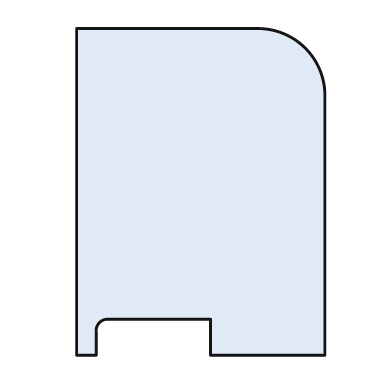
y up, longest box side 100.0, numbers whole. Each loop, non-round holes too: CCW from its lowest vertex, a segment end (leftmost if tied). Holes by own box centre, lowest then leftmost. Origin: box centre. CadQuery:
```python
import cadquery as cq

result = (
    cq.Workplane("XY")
    .moveTo(-38.0, -50.0)
    .lineTo(-32.0, -50.0)
    .lineTo(-32.0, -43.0)
    .threePointArc((-31.0, -40.0), (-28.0, -39.0))
    .lineTo(3.0, -39.0)
    .lineTo(3.0, -50.0)
    .lineTo(38.0, -50.0)
    .lineTo(38.0, 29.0)
    .threePointArc((32.0, 44.0), (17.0, 50.0))
    .lineTo(-38.0, 50.0)
    .close()
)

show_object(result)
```